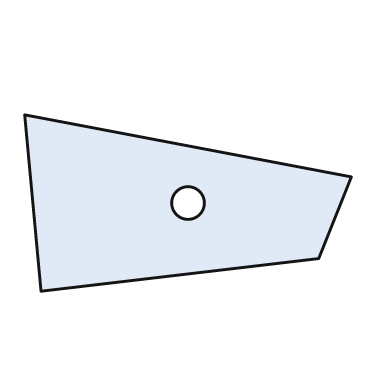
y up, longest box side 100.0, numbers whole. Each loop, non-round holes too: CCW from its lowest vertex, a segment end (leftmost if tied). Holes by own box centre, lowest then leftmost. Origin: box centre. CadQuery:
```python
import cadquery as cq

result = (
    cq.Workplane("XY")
    .moveTo(-45.0, -27.0)
    .lineTo(40.0, -17.0)
    .lineTo(50.0, 8.0)
    .lineTo(-50.0, 27.0)
    .close()
    .moveTo(0.0, 0.0)
    .circle(5.0)
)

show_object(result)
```